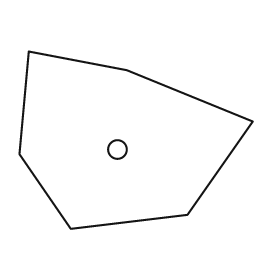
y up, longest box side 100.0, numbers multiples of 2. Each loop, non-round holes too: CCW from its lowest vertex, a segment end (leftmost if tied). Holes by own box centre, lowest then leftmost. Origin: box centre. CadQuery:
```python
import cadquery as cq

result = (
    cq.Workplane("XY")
    .moveTo(-28.0, -38.0)
    .lineTo(22.0, -32.0)
    .lineTo(50.0, 8.0)
    .lineTo(-4.0, 30.0)
    .lineTo(-46.0, 38.0)
    .lineTo(-50.0, -6.0)
    .close()
    .moveTo(-8.0, -4.0)
    .circle(4.0)
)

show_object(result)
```